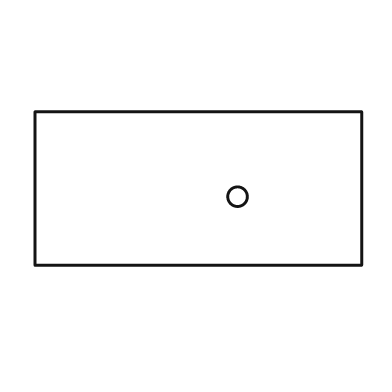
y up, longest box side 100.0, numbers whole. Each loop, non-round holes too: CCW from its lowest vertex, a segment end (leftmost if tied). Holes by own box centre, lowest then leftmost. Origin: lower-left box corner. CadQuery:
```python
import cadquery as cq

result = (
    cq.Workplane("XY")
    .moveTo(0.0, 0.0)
    .lineTo(100.0, 0.0)
    .lineTo(100.0, 47.0)
    .lineTo(0.0, 47.0)
    .close()
    .moveTo(62.0, 21.0)
    .circle(3.0)
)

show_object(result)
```